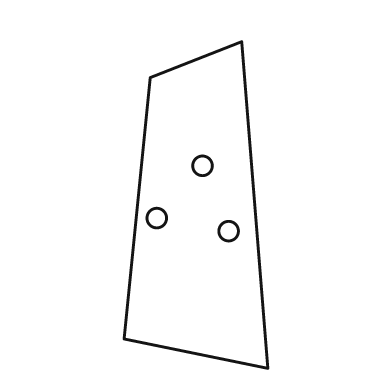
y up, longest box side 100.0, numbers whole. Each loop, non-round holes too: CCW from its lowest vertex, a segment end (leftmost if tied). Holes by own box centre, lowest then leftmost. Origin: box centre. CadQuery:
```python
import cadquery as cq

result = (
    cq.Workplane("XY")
    .moveTo(22.0, -50.0)
    .lineTo(14.0, 50.0)
    .lineTo(-14.0, 39.0)
    .lineTo(-22.0, -41.0)
    .close()
    .moveTo(10.0, -8.0)
    .circle(3.0)
    .moveTo(-12.0, -4.0)
    .circle(3.0)
    .moveTo(2.0, 12.0)
    .circle(3.0)
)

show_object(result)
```